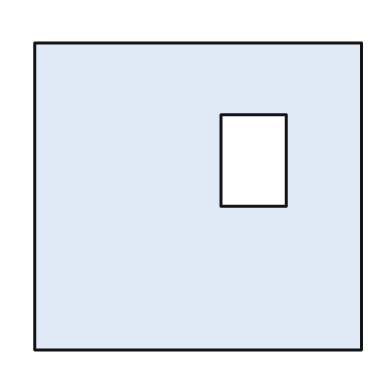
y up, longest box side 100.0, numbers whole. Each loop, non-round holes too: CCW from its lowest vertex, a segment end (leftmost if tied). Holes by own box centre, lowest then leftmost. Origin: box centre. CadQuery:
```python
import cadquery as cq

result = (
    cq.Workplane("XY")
    .moveTo(-50.0, -47.0)
    .lineTo(50.0, -47.0)
    .lineTo(50.0, 47.0)
    .lineTo(-50.0, 47.0)
    .close()
    .moveTo(7.0, -3.0)
    .lineTo(27.0, -3.0)
    .lineTo(27.0, 25.0)
    .lineTo(7.0, 25.0)
    .close()
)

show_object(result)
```